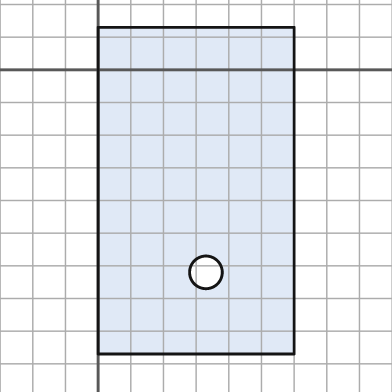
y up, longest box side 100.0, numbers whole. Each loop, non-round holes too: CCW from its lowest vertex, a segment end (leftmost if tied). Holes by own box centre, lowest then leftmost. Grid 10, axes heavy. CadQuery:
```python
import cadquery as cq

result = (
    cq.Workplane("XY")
    .moveTo(0.0, -87.0)
    .lineTo(60.0, -87.0)
    .lineTo(60.0, 13.0)
    .lineTo(0.0, 13.0)
    .close()
    .moveTo(33.0, -62.0)
    .circle(5.0)
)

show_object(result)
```